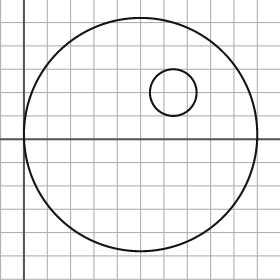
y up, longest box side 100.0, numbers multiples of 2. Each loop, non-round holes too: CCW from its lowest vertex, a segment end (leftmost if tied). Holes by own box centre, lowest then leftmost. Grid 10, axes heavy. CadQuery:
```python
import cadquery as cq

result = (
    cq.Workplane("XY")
    .moveTo(50.0, 2.0)
    .circle(50.0)
    .moveTo(64.0, 20.0)
    .circle(10.0)
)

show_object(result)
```